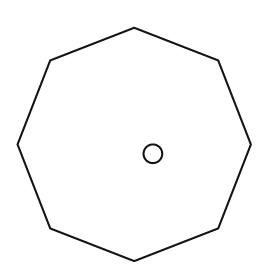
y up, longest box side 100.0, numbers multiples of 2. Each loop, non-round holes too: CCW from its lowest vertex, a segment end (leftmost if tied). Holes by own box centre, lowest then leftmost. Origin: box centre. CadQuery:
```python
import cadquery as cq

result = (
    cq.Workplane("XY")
    .moveTo(0.0, -50.0)
    .lineTo(36.0, -36.0)
    .lineTo(50.0, 0.0)
    .lineTo(36.0, 36.0)
    .lineTo(0.0, 50.0)
    .lineTo(-36.0, 36.0)
    .lineTo(-50.0, 0.0)
    .lineTo(-36.0, -36.0)
    .close()
    .moveTo(8.0, -4.0)
    .circle(4.0)
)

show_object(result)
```